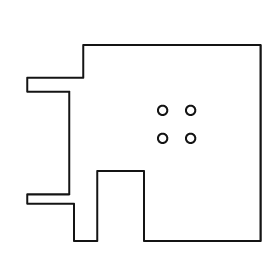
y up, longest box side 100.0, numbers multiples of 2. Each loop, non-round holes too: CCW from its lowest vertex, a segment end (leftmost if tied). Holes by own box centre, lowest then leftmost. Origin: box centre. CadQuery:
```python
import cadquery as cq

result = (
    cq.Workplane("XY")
    .moveTo(-30.0, -42.0)
    .lineTo(-20.0, -42.0)
    .lineTo(-20.0, -12.0)
    .lineTo(0.0, -12.0)
    .lineTo(0.0, -42.0)
    .lineTo(50.0, -42.0)
    .lineTo(50.0, 42.0)
    .lineTo(-26.0, 42.0)
    .lineTo(-26.0, 28.0)
    .lineTo(-50.0, 28.0)
    .lineTo(-50.0, 22.0)
    .lineTo(-32.0, 22.0)
    .lineTo(-32.0, -22.0)
    .lineTo(-50.0, -22.0)
    .lineTo(-50.0, -26.0)
    .lineTo(-30.0, -26.0)
    .close()
    .moveTo(8.0, 2.0)
    .circle(2.0)
    .moveTo(20.0, 2.0)
    .circle(2.0)
    .moveTo(8.0, 14.0)
    .circle(2.0)
    .moveTo(20.0, 14.0)
    .circle(2.0)
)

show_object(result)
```